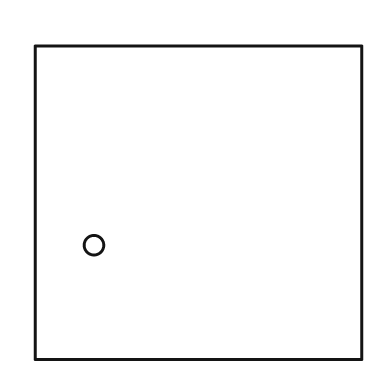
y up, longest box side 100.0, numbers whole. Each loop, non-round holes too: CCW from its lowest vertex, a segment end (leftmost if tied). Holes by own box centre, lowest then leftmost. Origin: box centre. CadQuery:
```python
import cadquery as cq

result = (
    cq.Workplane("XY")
    .moveTo(-50.0, -48.0)
    .lineTo(50.0, -48.0)
    .lineTo(50.0, 48.0)
    .lineTo(-50.0, 48.0)
    .close()
    .moveTo(-32.0, -13.0)
    .circle(3.0)
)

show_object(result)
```